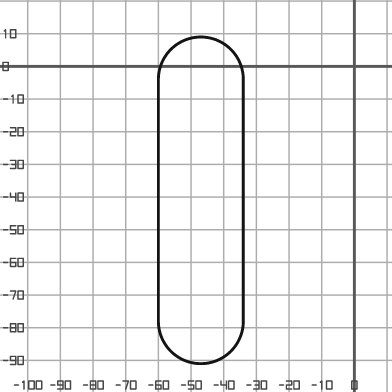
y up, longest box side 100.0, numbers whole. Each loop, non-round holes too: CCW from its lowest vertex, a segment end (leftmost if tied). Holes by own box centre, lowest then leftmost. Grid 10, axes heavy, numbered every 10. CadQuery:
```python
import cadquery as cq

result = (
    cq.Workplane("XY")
    .moveTo(-60.0, -78.0)
    .threePointArc((-47.0, -91.0), (-34.0, -78.0))
    .lineTo(-34.0, -4.0)
    .threePointArc((-47.0, 9.0), (-60.0, -4.0))
    .close()
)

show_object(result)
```